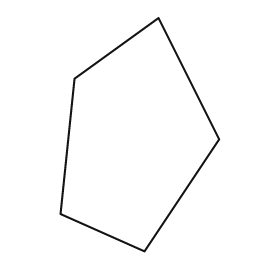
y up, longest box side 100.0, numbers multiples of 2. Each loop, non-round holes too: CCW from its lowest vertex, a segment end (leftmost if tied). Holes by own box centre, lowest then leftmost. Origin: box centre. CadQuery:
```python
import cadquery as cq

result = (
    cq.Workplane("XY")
    .moveTo(2.0, -50.0)
    .lineTo(34.0, -2.0)
    .lineTo(8.0, 50.0)
    .lineTo(-28.0, 24.0)
    .lineTo(-34.0, -34.0)
    .close()
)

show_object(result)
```